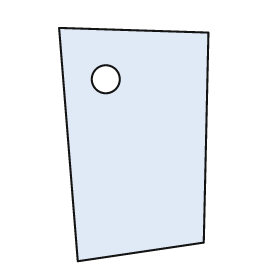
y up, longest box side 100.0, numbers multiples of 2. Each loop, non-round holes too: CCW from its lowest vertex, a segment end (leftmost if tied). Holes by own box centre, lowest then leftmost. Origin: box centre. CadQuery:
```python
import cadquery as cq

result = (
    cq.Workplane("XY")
    .moveTo(-24.0, -50.0)
    .lineTo(30.0, -42.0)
    .lineTo(32.0, 48.0)
    .lineTo(-32.0, 50.0)
    .close()
    .moveTo(-12.0, 28.0)
    .circle(6.0)
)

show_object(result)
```